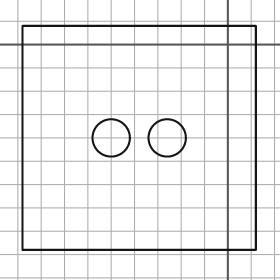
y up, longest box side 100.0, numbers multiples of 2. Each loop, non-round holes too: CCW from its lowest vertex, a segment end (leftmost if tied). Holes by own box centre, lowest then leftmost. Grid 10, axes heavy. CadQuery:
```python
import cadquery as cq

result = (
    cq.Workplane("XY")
    .moveTo(-88.0, -88.0)
    .lineTo(12.0, -88.0)
    .lineTo(12.0, 8.0)
    .lineTo(-88.0, 8.0)
    .close()
    .moveTo(-50.0, -40.0)
    .circle(8.0)
    .moveTo(-26.0, -40.0)
    .circle(8.0)
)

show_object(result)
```